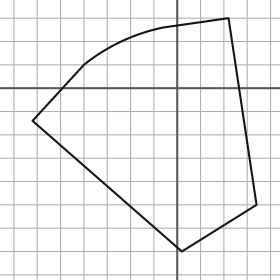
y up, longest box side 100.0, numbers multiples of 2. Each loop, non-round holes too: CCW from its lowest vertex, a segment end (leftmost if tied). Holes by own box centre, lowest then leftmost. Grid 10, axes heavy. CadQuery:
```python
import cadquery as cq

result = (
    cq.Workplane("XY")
    .moveTo(2.0, -70.0)
    .lineTo(34.0, -50.0)
    .lineTo(22.0, 30.0)
    .lineTo(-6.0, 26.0)
    .threePointArc((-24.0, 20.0), (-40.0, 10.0))
    .lineTo(-62.0, -14.0)
    .close()
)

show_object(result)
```